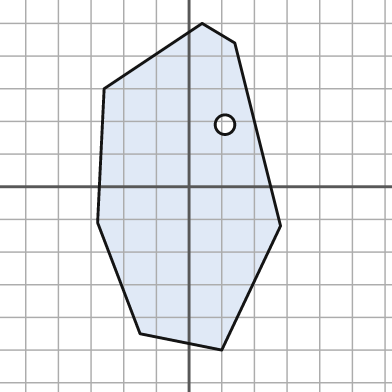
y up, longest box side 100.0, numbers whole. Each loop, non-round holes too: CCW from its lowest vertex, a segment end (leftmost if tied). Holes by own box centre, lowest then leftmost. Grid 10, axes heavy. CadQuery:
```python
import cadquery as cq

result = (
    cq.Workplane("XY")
    .moveTo(10.0, -50.0)
    .lineTo(28.0, -12.0)
    .lineTo(14.0, 44.0)
    .lineTo(4.0, 50.0)
    .lineTo(-26.0, 30.0)
    .lineTo(-28.0, -11.0)
    .lineTo(-15.0, -45.0)
    .close()
    .moveTo(11.0, 19.0)
    .circle(3.0)
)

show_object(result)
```